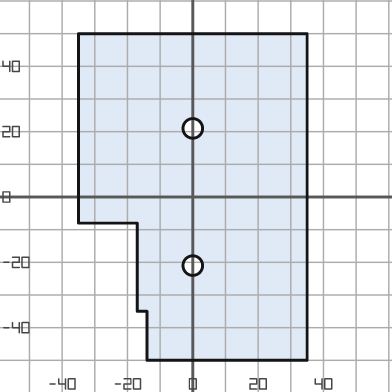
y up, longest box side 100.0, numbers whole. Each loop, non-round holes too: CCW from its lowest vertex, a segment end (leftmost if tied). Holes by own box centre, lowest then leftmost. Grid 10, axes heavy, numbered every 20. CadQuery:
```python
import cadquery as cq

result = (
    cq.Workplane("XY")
    .moveTo(-14.0, -50.0)
    .lineTo(35.0, -50.0)
    .lineTo(35.0, 50.0)
    .lineTo(-35.0, 50.0)
    .lineTo(-35.0, -8.0)
    .lineTo(-17.0, -8.0)
    .lineTo(-17.0, -35.0)
    .lineTo(-14.0, -35.0)
    .close()
    .moveTo(0.0, -21.0)
    .circle(3.0)
    .moveTo(0.0, 21.0)
    .circle(3.0)
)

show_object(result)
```